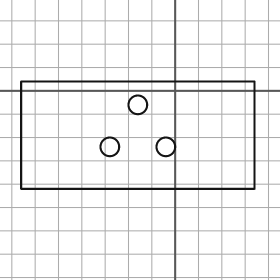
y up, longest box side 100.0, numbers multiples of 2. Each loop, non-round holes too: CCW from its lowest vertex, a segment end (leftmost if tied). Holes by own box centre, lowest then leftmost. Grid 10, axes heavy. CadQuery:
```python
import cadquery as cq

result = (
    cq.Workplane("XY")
    .moveTo(-66.0, -42.0)
    .lineTo(34.0, -42.0)
    .lineTo(34.0, 4.0)
    .lineTo(-66.0, 4.0)
    .close()
    .moveTo(-28.0, -24.0)
    .circle(4.0)
    .moveTo(-4.0, -24.0)
    .circle(4.0)
    .moveTo(-16.0, -6.0)
    .circle(4.0)
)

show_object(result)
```